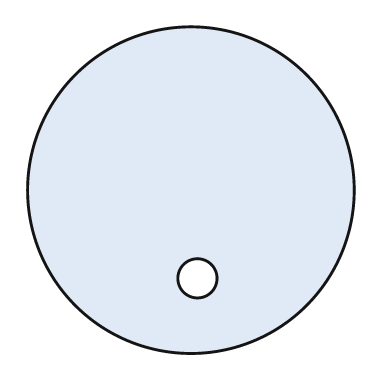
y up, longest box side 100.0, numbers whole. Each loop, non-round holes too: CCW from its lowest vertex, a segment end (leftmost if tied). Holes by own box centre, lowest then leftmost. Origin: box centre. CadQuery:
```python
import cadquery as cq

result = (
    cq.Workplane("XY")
    .moveTo(0.0, 0.0)
    .circle(50.0)
    .moveTo(2.0, -27.0)
    .circle(6.0)
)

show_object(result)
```